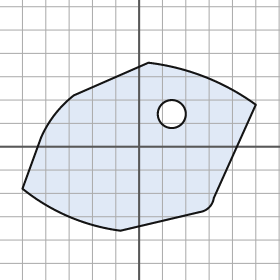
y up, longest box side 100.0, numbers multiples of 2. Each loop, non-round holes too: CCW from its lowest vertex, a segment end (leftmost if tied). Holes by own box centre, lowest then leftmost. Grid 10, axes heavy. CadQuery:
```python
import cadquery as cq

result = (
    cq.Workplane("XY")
    .moveTo(-8.0, -36.0)
    .lineTo(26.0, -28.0)
    .threePointArc((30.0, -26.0), (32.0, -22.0))
    .lineTo(50.0, 18.0)
    .threePointArc((28.0, 30.0), (4.0, 36.0))
    .lineTo(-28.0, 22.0)
    .threePointArc((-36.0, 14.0), (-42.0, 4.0))
    .lineTo(-50.0, -18.0)
    .threePointArc((-30.0, -30.0), (-8.0, -36.0))
    .close()
    .moveTo(14.0, 14.0)
    .circle(6.0)
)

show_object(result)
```